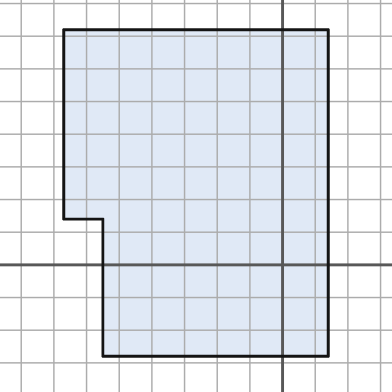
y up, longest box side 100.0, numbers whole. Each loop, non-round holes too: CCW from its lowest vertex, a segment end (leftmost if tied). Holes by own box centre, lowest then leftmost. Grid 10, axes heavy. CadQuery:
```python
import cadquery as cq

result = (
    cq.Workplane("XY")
    .moveTo(-55.0, -28.0)
    .lineTo(14.0, -28.0)
    .lineTo(14.0, 72.0)
    .lineTo(-67.0, 72.0)
    .lineTo(-67.0, 14.0)
    .lineTo(-55.0, 14.0)
    .close()
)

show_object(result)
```